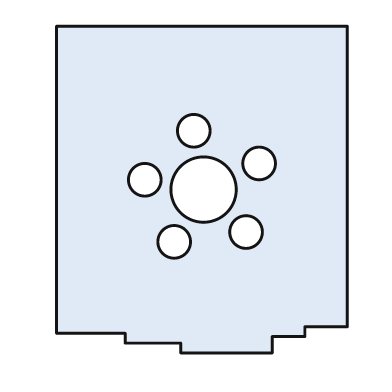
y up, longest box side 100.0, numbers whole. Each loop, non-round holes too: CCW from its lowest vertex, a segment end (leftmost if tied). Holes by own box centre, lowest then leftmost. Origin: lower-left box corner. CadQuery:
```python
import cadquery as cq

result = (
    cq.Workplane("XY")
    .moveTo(38.0, 0.0)
    .lineTo(66.0, 0.0)
    .lineTo(66.0, 5.0)
    .lineTo(76.0, 5.0)
    .lineTo(76.0, 8.0)
    .lineTo(89.0, 8.0)
    .lineTo(89.0, 100.0)
    .lineTo(0.0, 100.0)
    .lineTo(0.0, 6.0)
    .lineTo(21.0, 6.0)
    .lineTo(21.0, 3.0)
    .lineTo(38.0, 3.0)
    .close()
    .moveTo(36.0, 34.0)
    .circle(5.0)
    .moveTo(58.0, 37.0)
    .circle(5.0)
    .moveTo(45.0, 50.0)
    .circle(10.0)
    .moveTo(27.0, 53.0)
    .circle(5.0)
    .moveTo(62.0, 58.0)
    .circle(5.0)
    .moveTo(42.0, 68.0)
    .circle(5.0)
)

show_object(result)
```